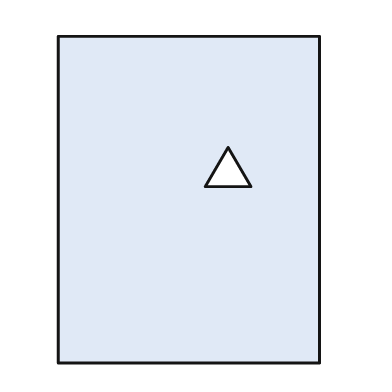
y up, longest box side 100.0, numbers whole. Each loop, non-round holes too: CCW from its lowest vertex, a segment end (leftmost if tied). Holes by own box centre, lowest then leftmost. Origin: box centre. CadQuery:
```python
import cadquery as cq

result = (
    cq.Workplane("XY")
    .moveTo(-40.0, -50.0)
    .lineTo(40.0, -50.0)
    .lineTo(40.0, 50.0)
    .lineTo(-40.0, 50.0)
    .close()
    .moveTo(5.0, 4.0)
    .lineTo(19.0, 4.0)
    .lineTo(12.0, 16.0)
    .close()
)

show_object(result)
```